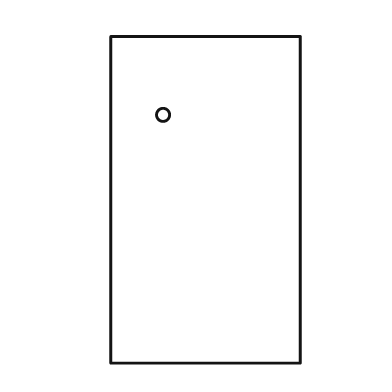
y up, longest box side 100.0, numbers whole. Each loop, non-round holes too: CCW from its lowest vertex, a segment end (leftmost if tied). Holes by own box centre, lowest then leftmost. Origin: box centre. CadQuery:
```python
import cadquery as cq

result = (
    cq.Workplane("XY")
    .moveTo(-29.0, -50.0)
    .lineTo(29.0, -50.0)
    .lineTo(29.0, 50.0)
    .lineTo(-29.0, 50.0)
    .close()
    .moveTo(-13.0, 26.0)
    .circle(2.0)
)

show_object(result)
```